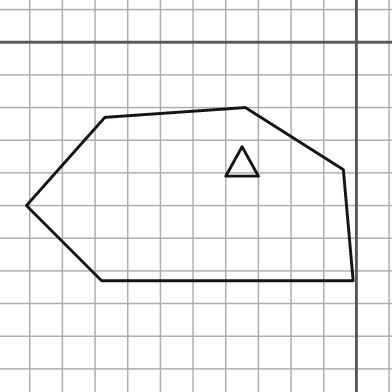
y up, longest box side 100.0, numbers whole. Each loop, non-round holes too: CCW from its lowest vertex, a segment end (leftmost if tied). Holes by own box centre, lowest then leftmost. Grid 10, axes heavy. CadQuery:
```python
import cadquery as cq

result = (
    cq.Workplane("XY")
    .moveTo(-78.0, -73.0)
    .lineTo(-1.0, -73.0)
    .lineTo(-4.0, -39.0)
    .lineTo(-34.0, -20.0)
    .lineTo(-77.0, -23.0)
    .lineTo(-101.0, -50.0)
    .close()
    .moveTo(-40.0, -41.0)
    .lineTo(-30.0, -41.0)
    .lineTo(-35.0, -32.0)
    .close()
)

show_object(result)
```